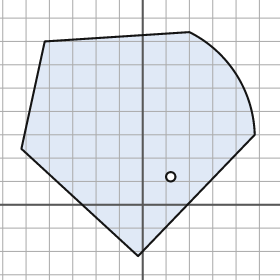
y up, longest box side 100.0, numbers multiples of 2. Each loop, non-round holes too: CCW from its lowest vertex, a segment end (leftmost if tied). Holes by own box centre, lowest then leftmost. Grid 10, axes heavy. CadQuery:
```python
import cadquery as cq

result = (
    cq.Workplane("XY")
    .moveTo(-2.0, -22.0)
    .lineTo(48.0, 30.0)
    .threePointArc((40.0, 56.0), (20.0, 74.0))
    .lineTo(-42.0, 70.0)
    .lineTo(-52.0, 24.0)
    .close()
    .moveTo(12.0, 12.0)
    .circle(2.0)
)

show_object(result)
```